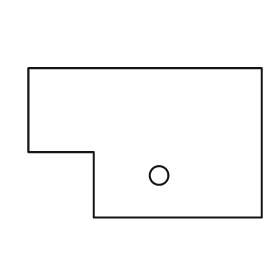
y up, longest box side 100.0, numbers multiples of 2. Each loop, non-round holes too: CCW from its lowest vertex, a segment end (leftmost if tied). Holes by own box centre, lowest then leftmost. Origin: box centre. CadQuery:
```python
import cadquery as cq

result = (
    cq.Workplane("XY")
    .moveTo(-22.0, -32.0)
    .lineTo(50.0, -32.0)
    .lineTo(50.0, 32.0)
    .lineTo(-50.0, 32.0)
    .lineTo(-50.0, -4.0)
    .lineTo(-22.0, -4.0)
    .close()
    .moveTo(6.0, -14.0)
    .circle(4.0)
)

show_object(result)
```